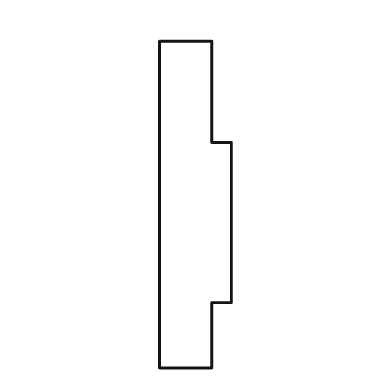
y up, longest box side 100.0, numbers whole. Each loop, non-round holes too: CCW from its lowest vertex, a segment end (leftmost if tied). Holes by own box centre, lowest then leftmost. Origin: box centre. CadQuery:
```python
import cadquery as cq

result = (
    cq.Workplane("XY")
    .moveTo(-11.0, -50.0)
    .lineTo(5.0, -50.0)
    .lineTo(5.0, -30.0)
    .lineTo(11.0, -30.0)
    .lineTo(11.0, 19.0)
    .lineTo(5.0, 19.0)
    .lineTo(5.0, 50.0)
    .lineTo(-11.0, 50.0)
    .close()
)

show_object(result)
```